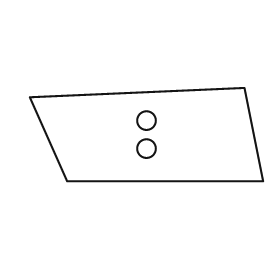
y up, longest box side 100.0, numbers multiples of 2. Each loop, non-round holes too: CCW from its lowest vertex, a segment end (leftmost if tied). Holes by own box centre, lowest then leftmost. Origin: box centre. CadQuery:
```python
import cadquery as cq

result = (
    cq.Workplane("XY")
    .moveTo(-34.0, -20.0)
    .lineTo(50.0, -20.0)
    .lineTo(42.0, 20.0)
    .lineTo(-50.0, 16.0)
    .close()
    .moveTo(0.0, -6.0)
    .circle(4.0)
    .moveTo(0.0, 6.0)
    .circle(4.0)
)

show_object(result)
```